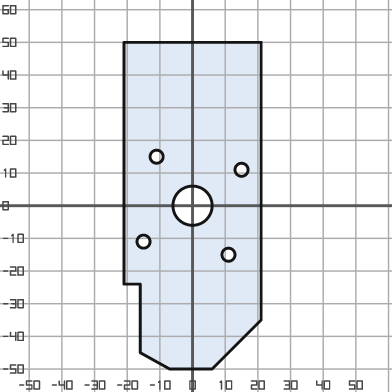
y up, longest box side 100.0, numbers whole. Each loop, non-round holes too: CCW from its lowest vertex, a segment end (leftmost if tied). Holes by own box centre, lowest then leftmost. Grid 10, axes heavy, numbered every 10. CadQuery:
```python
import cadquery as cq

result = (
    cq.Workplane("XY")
    .moveTo(-7.0, -50.0)
    .lineTo(6.0, -50.0)
    .lineTo(21.0, -35.0)
    .lineTo(21.0, 50.0)
    .lineTo(-21.0, 50.0)
    .lineTo(-21.0, -24.0)
    .lineTo(-16.0, -24.0)
    .lineTo(-16.0, -45.0)
    .close()
    .moveTo(11.0, -15.0)
    .circle(2.0)
    .moveTo(-15.0, -11.0)
    .circle(2.0)
    .moveTo(0.0, 0.0)
    .circle(6.0)
    .moveTo(15.0, 11.0)
    .circle(2.0)
    .moveTo(-11.0, 15.0)
    .circle(2.0)
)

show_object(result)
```